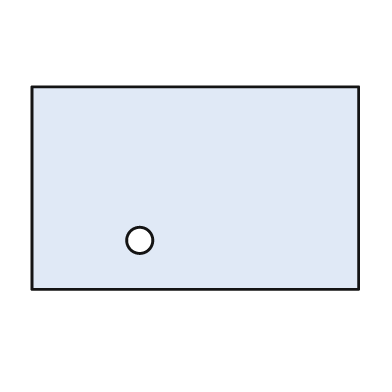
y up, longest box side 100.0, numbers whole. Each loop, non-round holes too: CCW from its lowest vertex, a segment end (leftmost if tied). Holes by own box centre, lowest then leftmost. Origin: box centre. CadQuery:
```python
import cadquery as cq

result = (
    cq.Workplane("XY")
    .moveTo(-50.0, -31.0)
    .lineTo(50.0, -31.0)
    .lineTo(50.0, 31.0)
    .lineTo(-50.0, 31.0)
    .close()
    .moveTo(-17.0, -16.0)
    .circle(4.0)
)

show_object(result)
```